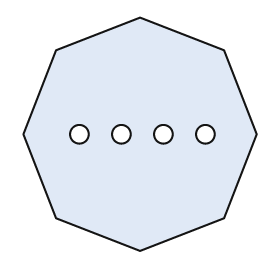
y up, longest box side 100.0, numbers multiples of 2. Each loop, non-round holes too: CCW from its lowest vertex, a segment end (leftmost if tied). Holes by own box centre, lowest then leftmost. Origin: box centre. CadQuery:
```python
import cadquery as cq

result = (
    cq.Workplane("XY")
    .moveTo(0.0, -50.0)
    .lineTo(36.0, -36.0)
    .lineTo(50.0, 0.0)
    .lineTo(36.0, 36.0)
    .lineTo(0.0, 50.0)
    .lineTo(-36.0, 36.0)
    .lineTo(-50.0, 0.0)
    .lineTo(-36.0, -36.0)
    .close()
    .moveTo(-26.0, 0.0)
    .circle(4.0)
    .moveTo(-8.0, 0.0)
    .circle(4.0)
    .moveTo(10.0, 0.0)
    .circle(4.0)
    .moveTo(28.0, 0.0)
    .circle(4.0)
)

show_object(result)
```